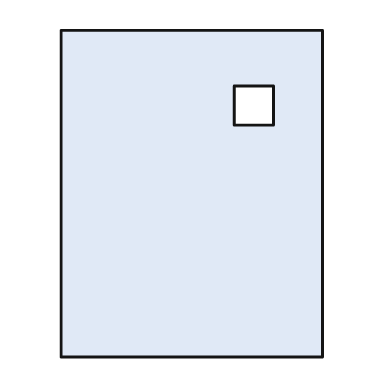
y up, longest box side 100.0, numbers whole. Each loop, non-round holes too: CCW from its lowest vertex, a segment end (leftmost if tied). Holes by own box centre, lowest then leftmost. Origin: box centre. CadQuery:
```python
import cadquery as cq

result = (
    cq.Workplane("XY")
    .moveTo(-40.0, -50.0)
    .lineTo(40.0, -50.0)
    .lineTo(40.0, 50.0)
    .lineTo(-40.0, 50.0)
    .close()
    .moveTo(13.0, 21.0)
    .lineTo(25.0, 21.0)
    .lineTo(25.0, 33.0)
    .lineTo(13.0, 33.0)
    .close()
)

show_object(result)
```